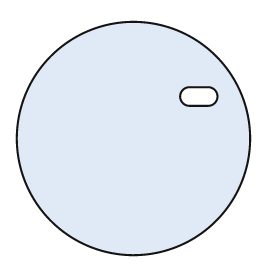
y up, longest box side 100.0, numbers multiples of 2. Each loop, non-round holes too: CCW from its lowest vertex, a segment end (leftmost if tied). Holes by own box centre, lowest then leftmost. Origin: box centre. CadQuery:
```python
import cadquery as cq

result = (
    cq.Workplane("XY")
    .moveTo(0.0, 0.0)
    .circle(50.0)
    .moveTo(24.0, 14.0)
    .lineTo(32.0, 14.0)
    .threePointArc((36.0, 18.0), (32.0, 22.0))
    .lineTo(24.0, 22.0)
    .threePointArc((20.0, 18.0), (24.0, 14.0))
    .close()
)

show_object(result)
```